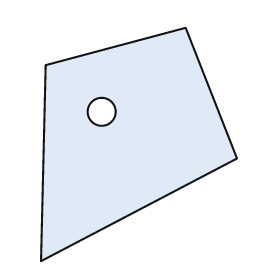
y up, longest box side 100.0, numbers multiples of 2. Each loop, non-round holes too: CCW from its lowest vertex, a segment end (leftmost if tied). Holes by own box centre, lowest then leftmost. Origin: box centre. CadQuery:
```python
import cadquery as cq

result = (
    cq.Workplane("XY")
    .moveTo(-42.0, -50.0)
    .lineTo(42.0, -6.0)
    .lineTo(20.0, 50.0)
    .lineTo(-40.0, 34.0)
    .close()
    .moveTo(-16.0, 14.0)
    .circle(6.0)
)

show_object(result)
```